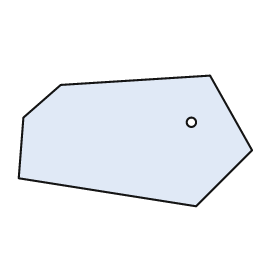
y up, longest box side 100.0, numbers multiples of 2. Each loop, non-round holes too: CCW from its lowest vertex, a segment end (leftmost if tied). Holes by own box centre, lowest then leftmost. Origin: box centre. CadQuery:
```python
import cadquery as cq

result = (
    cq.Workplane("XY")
    .moveTo(26.0, -28.0)
    .lineTo(50.0, -4.0)
    .lineTo(32.0, 28.0)
    .lineTo(-32.0, 24.0)
    .lineTo(-48.0, 10.0)
    .lineTo(-50.0, -16.0)
    .close()
    .moveTo(24.0, 8.0)
    .circle(2.0)
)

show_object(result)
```